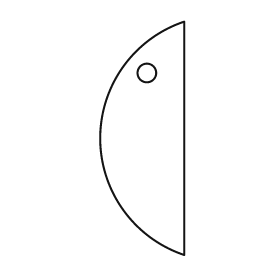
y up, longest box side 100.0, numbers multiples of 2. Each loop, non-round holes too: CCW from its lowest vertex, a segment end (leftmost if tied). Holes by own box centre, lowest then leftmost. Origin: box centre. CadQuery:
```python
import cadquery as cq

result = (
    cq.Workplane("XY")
    .moveTo(18.0, -50.0)
    .lineTo(18.0, 50.0)
    .threePointArc((-18.0, 0.0), (18.0, -50.0))
    .close()
    .moveTo(2.0, 28.0)
    .circle(4.0)
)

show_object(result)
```